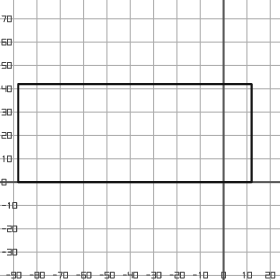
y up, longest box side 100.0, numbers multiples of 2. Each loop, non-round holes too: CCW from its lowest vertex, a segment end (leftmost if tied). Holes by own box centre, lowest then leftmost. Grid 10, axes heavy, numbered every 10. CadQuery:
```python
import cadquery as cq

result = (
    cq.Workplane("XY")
    .moveTo(-88.0, 0.0)
    .lineTo(12.0, 0.0)
    .lineTo(12.0, 42.0)
    .lineTo(-88.0, 42.0)
    .close()
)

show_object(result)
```